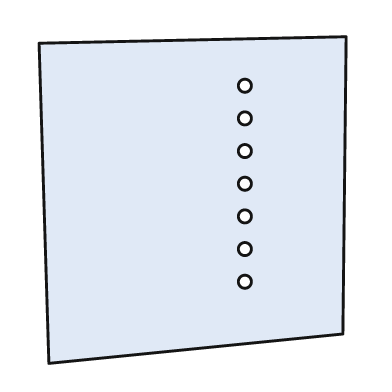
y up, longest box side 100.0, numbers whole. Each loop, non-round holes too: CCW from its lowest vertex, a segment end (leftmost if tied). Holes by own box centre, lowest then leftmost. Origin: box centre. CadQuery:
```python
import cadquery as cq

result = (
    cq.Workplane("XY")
    .moveTo(-44.0, -50.0)
    .lineTo(46.0, -41.0)
    .lineTo(47.0, 50.0)
    .lineTo(-47.0, 48.0)
    .close()
    .moveTo(16.0, -25.0)
    .circle(2.0)
    .moveTo(16.0, -15.0)
    .circle(2.0)
    .moveTo(16.0, -5.0)
    .circle(2.0)
    .moveTo(16.0, 5.0)
    .circle(2.0)
    .moveTo(16.0, 15.0)
    .circle(2.0)
    .moveTo(16.0, 25.0)
    .circle(2.0)
    .moveTo(16.0, 35.0)
    .circle(2.0)
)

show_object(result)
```